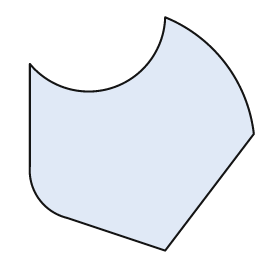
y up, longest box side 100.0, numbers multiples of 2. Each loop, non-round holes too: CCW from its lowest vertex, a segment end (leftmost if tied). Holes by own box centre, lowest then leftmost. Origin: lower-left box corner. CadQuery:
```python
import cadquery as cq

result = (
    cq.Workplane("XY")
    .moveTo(58.0, 0.0)
    .lineTo(96.0, 50.0)
    .threePointArc((84.0, 80.0), (58.0, 100.0))
    .threePointArc((36.0, 70.0), (0.0, 80.0))
    .lineTo(0.0, 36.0)
    .threePointArc((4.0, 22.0), (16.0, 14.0))
    .close()
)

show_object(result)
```